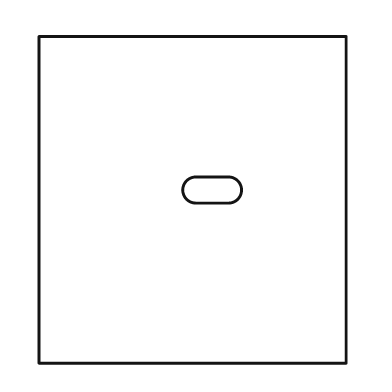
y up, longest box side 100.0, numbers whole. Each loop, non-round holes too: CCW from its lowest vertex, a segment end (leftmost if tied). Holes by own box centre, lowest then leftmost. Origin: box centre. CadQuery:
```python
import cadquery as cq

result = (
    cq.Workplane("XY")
    .moveTo(-47.0, -50.0)
    .lineTo(47.0, -50.0)
    .lineTo(47.0, 50.0)
    .lineTo(-47.0, 50.0)
    .close()
    .moveTo(1.0, -1.0)
    .lineTo(11.0, -1.0)
    .threePointArc((15.0, 3.0), (11.0, 7.0))
    .lineTo(1.0, 7.0)
    .threePointArc((-3.0, 3.0), (1.0, -1.0))
    .close()
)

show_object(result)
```